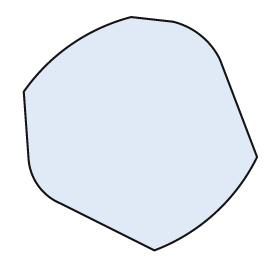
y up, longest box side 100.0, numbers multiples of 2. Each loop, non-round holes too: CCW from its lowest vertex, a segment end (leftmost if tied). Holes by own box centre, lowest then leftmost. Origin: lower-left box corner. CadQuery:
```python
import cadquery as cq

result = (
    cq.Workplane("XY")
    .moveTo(56.0, 0.0)
    .threePointArc((82.0, 16.0), (100.0, 40.0))
    .lineTo(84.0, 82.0)
    .threePointArc((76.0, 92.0), (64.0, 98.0))
    .lineTo(46.0, 100.0)
    .threePointArc((20.0, 88.0), (0.0, 68.0))
    .lineTo(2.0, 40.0)
    .threePointArc((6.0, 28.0), (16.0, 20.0))
    .close()
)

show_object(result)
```